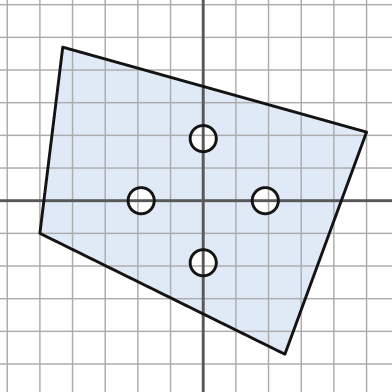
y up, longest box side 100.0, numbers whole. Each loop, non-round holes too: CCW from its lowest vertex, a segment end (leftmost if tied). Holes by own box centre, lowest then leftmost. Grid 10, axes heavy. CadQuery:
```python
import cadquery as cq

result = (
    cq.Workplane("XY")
    .moveTo(25.0, -47.0)
    .lineTo(50.0, 21.0)
    .lineTo(-43.0, 47.0)
    .lineTo(-50.0, -10.0)
    .close()
    .moveTo(0.0, -19.0)
    .circle(4.0)
    .moveTo(-19.0, 0.0)
    .circle(4.0)
    .moveTo(19.0, 0.0)
    .circle(4.0)
    .moveTo(0.0, 19.0)
    .circle(4.0)
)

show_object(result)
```